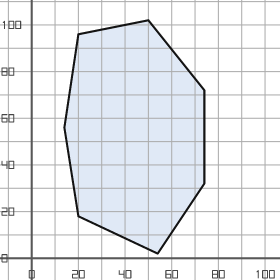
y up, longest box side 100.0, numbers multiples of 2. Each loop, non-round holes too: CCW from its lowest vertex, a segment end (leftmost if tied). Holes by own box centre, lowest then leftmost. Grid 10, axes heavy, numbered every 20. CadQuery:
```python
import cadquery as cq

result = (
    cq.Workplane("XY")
    .moveTo(54.0, 2.0)
    .lineTo(74.0, 32.0)
    .lineTo(74.0, 72.0)
    .lineTo(50.0, 102.0)
    .lineTo(20.0, 96.0)
    .lineTo(14.0, 56.0)
    .lineTo(20.0, 18.0)
    .close()
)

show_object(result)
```